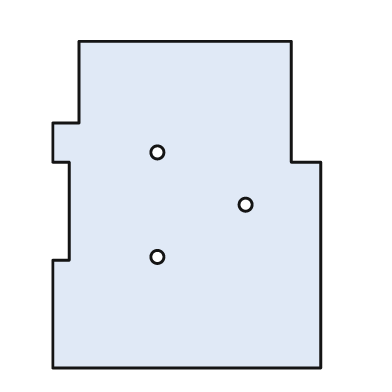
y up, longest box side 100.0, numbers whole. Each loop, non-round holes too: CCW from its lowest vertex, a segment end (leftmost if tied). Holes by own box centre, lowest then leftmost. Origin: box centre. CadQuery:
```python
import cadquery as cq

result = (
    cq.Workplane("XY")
    .moveTo(-41.0, -50.0)
    .lineTo(41.0, -50.0)
    .lineTo(41.0, 13.0)
    .lineTo(32.0, 13.0)
    .lineTo(32.0, 50.0)
    .lineTo(-33.0, 50.0)
    .lineTo(-33.0, 25.0)
    .lineTo(-41.0, 25.0)
    .lineTo(-41.0, 13.0)
    .lineTo(-36.0, 13.0)
    .lineTo(-36.0, -17.0)
    .lineTo(-41.0, -17.0)
    .close()
    .moveTo(-9.0, -16.0)
    .circle(2.0)
    .moveTo(18.0, 0.0)
    .circle(2.0)
    .moveTo(-9.0, 16.0)
    .circle(2.0)
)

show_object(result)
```